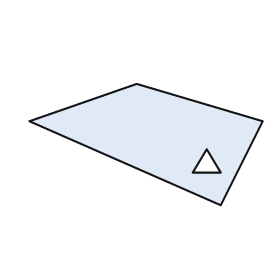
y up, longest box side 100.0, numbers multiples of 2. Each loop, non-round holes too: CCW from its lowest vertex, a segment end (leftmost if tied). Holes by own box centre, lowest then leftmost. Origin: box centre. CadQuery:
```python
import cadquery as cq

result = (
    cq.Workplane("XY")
    .moveTo(32.0, -26.0)
    .lineTo(50.0, 10.0)
    .lineTo(-4.0, 26.0)
    .lineTo(-50.0, 10.0)
    .close()
    .moveTo(20.0, -12.0)
    .lineTo(32.0, -12.0)
    .lineTo(26.0, -2.0)
    .close()
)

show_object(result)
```